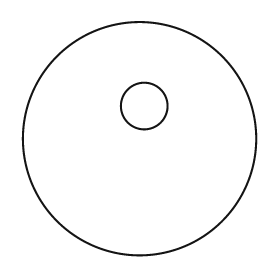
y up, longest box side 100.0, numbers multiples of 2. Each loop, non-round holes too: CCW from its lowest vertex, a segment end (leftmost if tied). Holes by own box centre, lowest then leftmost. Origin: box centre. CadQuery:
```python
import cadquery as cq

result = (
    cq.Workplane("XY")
    .moveTo(0.0, 0.0)
    .circle(50.0)
    .moveTo(2.0, 14.0)
    .circle(10.0)
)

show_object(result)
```